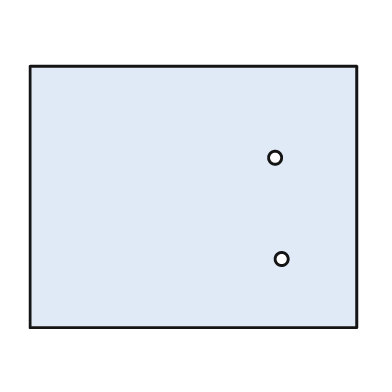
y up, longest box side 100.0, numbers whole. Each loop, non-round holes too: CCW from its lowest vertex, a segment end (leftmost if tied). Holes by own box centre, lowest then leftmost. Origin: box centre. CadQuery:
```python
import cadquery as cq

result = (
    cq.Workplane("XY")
    .moveTo(-50.0, -40.0)
    .lineTo(50.0, -40.0)
    .lineTo(50.0, 40.0)
    .lineTo(-50.0, 40.0)
    .close()
    .moveTo(27.0, -19.0)
    .circle(2.0)
    .moveTo(25.0, 12.0)
    .circle(2.0)
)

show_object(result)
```